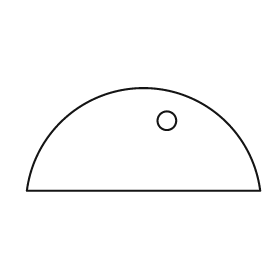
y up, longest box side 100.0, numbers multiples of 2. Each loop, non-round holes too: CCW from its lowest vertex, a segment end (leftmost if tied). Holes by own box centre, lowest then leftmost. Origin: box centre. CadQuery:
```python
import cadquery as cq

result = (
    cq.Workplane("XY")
    .moveTo(-50.0, -22.0)
    .lineTo(50.0, -22.0)
    .threePointArc((0.0, 22.0), (-50.0, -22.0))
    .close()
    .moveTo(10.0, 8.0)
    .circle(4.0)
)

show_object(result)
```